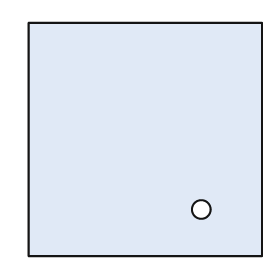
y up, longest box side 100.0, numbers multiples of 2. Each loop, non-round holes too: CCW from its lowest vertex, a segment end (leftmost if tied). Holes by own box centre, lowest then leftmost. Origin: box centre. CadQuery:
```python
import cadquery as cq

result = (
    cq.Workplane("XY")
    .moveTo(-50.0, -50.0)
    .lineTo(50.0, -50.0)
    .lineTo(50.0, 50.0)
    .lineTo(-50.0, 50.0)
    .close()
    .moveTo(24.0, -30.0)
    .circle(4.0)
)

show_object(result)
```